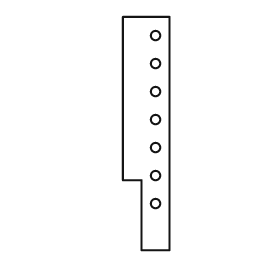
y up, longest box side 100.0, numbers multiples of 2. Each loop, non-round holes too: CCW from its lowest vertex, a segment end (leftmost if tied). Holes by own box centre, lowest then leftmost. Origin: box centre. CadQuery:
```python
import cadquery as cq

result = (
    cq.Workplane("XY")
    .moveTo(-2.0, -50.0)
    .lineTo(10.0, -50.0)
    .lineTo(10.0, 50.0)
    .lineTo(-10.0, 50.0)
    .lineTo(-10.0, -20.0)
    .lineTo(-2.0, -20.0)
    .close()
    .moveTo(4.0, -30.0)
    .circle(2.0)
    .moveTo(4.0, -18.0)
    .circle(2.0)
    .moveTo(4.0, -6.0)
    .circle(2.0)
    .moveTo(4.0, 6.0)
    .circle(2.0)
    .moveTo(4.0, 18.0)
    .circle(2.0)
    .moveTo(4.0, 30.0)
    .circle(2.0)
    .moveTo(4.0, 42.0)
    .circle(2.0)
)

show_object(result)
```